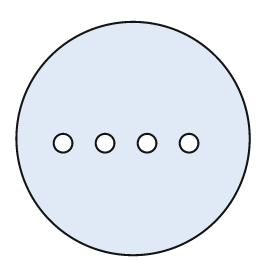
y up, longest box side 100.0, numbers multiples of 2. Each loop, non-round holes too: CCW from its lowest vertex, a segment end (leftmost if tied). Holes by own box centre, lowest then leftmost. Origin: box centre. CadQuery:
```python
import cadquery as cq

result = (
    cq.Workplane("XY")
    .moveTo(0.0, 0.0)
    .circle(50.0)
    .moveTo(-30.0, -2.0)
    .circle(4.0)
    .moveTo(-12.0, -2.0)
    .circle(4.0)
    .moveTo(6.0, -2.0)
    .circle(4.0)
    .moveTo(24.0, -2.0)
    .circle(4.0)
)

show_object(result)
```